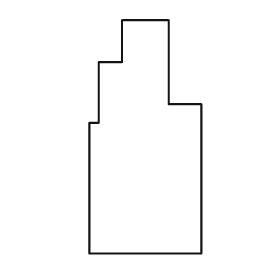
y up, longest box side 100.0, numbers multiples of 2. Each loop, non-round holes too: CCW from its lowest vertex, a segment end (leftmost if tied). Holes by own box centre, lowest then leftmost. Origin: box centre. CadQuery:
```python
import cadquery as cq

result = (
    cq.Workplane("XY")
    .moveTo(-24.0, -50.0)
    .lineTo(24.0, -50.0)
    .lineTo(24.0, 14.0)
    .lineTo(10.0, 14.0)
    .lineTo(10.0, 50.0)
    .lineTo(-10.0, 50.0)
    .lineTo(-10.0, 32.0)
    .lineTo(-20.0, 32.0)
    .lineTo(-20.0, 6.0)
    .lineTo(-24.0, 6.0)
    .close()
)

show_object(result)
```